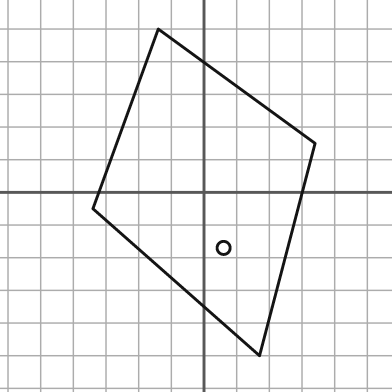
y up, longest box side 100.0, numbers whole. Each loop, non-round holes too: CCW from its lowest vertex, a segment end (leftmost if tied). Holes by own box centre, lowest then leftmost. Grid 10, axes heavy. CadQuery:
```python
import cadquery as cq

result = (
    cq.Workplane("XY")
    .moveTo(17.0, -50.0)
    .lineTo(34.0, 15.0)
    .lineTo(-14.0, 50.0)
    .lineTo(-34.0, -5.0)
    .close()
    .moveTo(6.0, -17.0)
    .circle(2.0)
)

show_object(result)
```